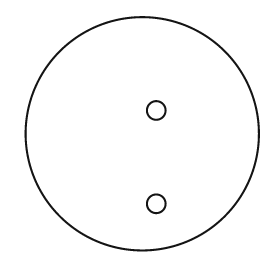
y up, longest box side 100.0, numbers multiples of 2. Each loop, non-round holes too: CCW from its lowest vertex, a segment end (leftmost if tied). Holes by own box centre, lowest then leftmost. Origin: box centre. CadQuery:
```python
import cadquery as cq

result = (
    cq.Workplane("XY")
    .moveTo(0.0, 0.0)
    .circle(50.0)
    .moveTo(6.0, -30.0)
    .circle(4.0)
    .moveTo(6.0, 10.0)
    .circle(4.0)
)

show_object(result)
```